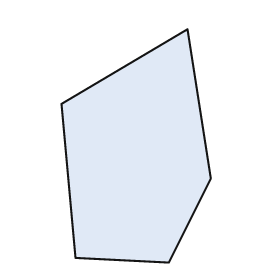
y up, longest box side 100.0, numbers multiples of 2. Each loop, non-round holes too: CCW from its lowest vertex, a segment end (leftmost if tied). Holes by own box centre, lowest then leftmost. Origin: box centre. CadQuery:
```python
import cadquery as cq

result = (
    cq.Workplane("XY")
    .moveTo(14.0, -50.0)
    .lineTo(32.0, -14.0)
    .lineTo(22.0, 50.0)
    .lineTo(-32.0, 18.0)
    .lineTo(-26.0, -48.0)
    .close()
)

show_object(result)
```